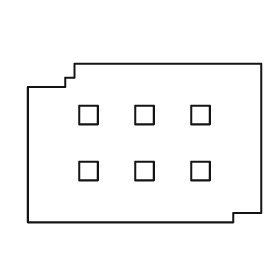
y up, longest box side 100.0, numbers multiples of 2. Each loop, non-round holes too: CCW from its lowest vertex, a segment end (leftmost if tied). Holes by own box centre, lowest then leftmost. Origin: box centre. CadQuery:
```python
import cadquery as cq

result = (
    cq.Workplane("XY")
    .moveTo(-50.0, -34.0)
    .lineTo(38.0, -34.0)
    .lineTo(38.0, -30.0)
    .lineTo(50.0, -30.0)
    .lineTo(50.0, 34.0)
    .lineTo(-30.0, 34.0)
    .lineTo(-30.0, 28.0)
    .lineTo(-34.0, 28.0)
    .lineTo(-34.0, 24.0)
    .lineTo(-50.0, 24.0)
    .close()
    .moveTo(-28.0, -16.0)
    .lineTo(-20.0, -16.0)
    .lineTo(-20.0, -8.0)
    .lineTo(-28.0, -8.0)
    .close()
    .moveTo(-4.0, -16.0)
    .lineTo(4.0, -16.0)
    .lineTo(4.0, -8.0)
    .lineTo(-4.0, -8.0)
    .close()
    .moveTo(20.0, -16.0)
    .lineTo(28.0, -16.0)
    .lineTo(28.0, -8.0)
    .lineTo(20.0, -8.0)
    .close()
    .moveTo(-28.0, 8.0)
    .lineTo(-20.0, 8.0)
    .lineTo(-20.0, 16.0)
    .lineTo(-28.0, 16.0)
    .close()
    .moveTo(-4.0, 8.0)
    .lineTo(4.0, 8.0)
    .lineTo(4.0, 16.0)
    .lineTo(-4.0, 16.0)
    .close()
    .moveTo(20.0, 8.0)
    .lineTo(28.0, 8.0)
    .lineTo(28.0, 16.0)
    .lineTo(20.0, 16.0)
    .close()
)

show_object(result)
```